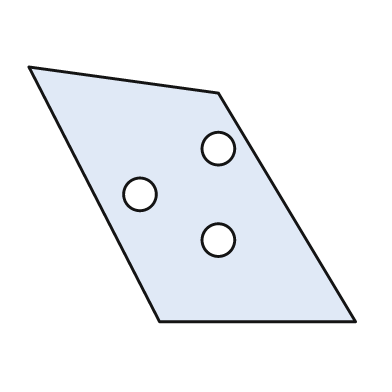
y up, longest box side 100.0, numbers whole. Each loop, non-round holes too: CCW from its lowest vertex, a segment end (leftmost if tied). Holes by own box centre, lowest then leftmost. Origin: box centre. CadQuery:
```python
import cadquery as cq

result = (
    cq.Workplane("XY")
    .moveTo(-10.0, -39.0)
    .lineTo(50.0, -39.0)
    .lineTo(8.0, 31.0)
    .lineTo(-50.0, 39.0)
    .close()
    .moveTo(8.0, -14.0)
    .circle(5.0)
    .moveTo(-16.0, 0.0)
    .circle(5.0)
    .moveTo(8.0, 14.0)
    .circle(5.0)
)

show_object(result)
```